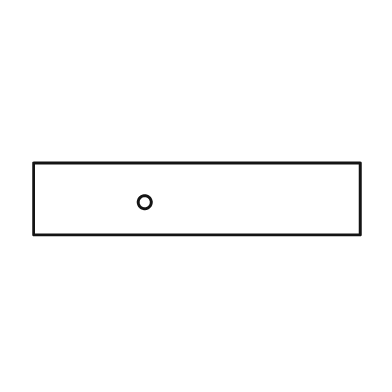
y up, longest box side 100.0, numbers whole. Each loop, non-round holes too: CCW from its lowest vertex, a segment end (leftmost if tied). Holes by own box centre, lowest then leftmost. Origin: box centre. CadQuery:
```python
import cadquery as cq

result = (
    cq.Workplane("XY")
    .moveTo(-50.0, -11.0)
    .lineTo(50.0, -11.0)
    .lineTo(50.0, 11.0)
    .lineTo(-50.0, 11.0)
    .close()
    .moveTo(-16.0, -1.0)
    .circle(2.0)
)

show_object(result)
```